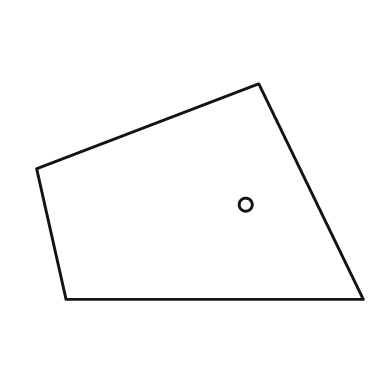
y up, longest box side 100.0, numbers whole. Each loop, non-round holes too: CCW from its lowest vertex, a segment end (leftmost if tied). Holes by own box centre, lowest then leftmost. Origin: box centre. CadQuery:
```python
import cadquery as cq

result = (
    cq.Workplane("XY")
    .moveTo(-41.0, -33.0)
    .lineTo(50.0, -33.0)
    .lineTo(18.0, 33.0)
    .lineTo(-50.0, 7.0)
    .close()
    .moveTo(14.0, -4.0)
    .circle(2.0)
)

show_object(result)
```